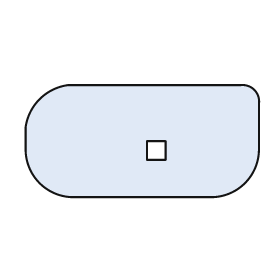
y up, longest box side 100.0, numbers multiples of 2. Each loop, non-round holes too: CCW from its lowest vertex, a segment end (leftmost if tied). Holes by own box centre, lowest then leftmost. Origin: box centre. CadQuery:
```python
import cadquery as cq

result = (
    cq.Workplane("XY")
    .moveTo(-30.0, -24.0)
    .lineTo(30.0, -24.0)
    .threePointArc((44.0, -18.0), (50.0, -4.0))
    .lineTo(50.0, 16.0)
    .threePointArc((48.0, 22.0), (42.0, 24.0))
    .lineTo(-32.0, 24.0)
    .threePointArc((-44.0, 18.0), (-50.0, 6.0))
    .lineTo(-50.0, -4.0)
    .threePointArc((-44.0, -18.0), (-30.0, -24.0))
    .close()
    .moveTo(2.0, -8.0)
    .lineTo(10.0, -8.0)
    .lineTo(10.0, 0.0)
    .lineTo(2.0, 0.0)
    .close()
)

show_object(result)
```